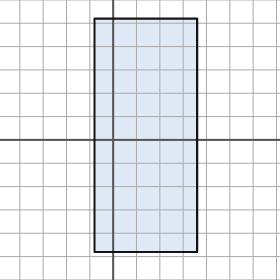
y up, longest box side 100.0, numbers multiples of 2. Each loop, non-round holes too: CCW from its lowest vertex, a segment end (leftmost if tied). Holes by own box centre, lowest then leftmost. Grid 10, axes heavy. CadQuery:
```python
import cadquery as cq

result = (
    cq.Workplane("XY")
    .moveTo(-8.0, -48.0)
    .lineTo(36.0, -48.0)
    .lineTo(36.0, 52.0)
    .lineTo(-8.0, 52.0)
    .close()
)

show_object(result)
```